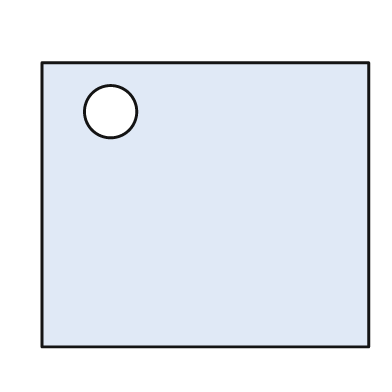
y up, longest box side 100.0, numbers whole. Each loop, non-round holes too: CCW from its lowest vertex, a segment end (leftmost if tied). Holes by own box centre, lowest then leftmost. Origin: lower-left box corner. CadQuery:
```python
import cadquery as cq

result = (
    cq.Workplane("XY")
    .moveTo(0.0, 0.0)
    .lineTo(100.0, 0.0)
    .lineTo(100.0, 87.0)
    .lineTo(0.0, 87.0)
    .close()
    .moveTo(21.0, 72.0)
    .circle(8.0)
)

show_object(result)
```